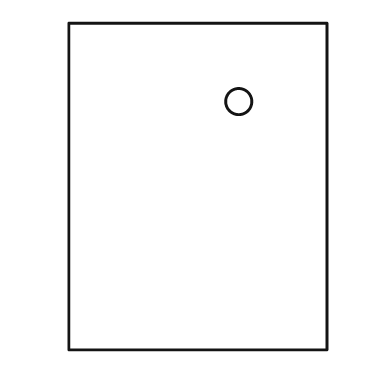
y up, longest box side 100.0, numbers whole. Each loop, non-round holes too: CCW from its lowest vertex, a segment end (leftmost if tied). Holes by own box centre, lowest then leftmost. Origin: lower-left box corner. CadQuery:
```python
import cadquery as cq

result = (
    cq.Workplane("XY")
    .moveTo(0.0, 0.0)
    .lineTo(79.0, 0.0)
    .lineTo(79.0, 100.0)
    .lineTo(0.0, 100.0)
    .close()
    .moveTo(52.0, 76.0)
    .circle(4.0)
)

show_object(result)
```